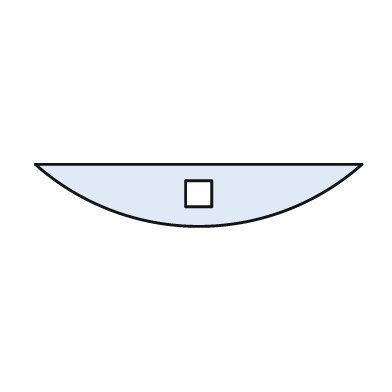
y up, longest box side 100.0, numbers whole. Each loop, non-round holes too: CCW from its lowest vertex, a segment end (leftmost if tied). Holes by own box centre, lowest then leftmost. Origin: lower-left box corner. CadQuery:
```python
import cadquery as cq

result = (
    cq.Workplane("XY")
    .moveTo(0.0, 19.0)
    .threePointArc((50.0, 0.0), (100.0, 19.0))
    .close()
    .moveTo(46.0, 6.0)
    .lineTo(54.0, 6.0)
    .lineTo(54.0, 14.0)
    .lineTo(46.0, 14.0)
    .close()
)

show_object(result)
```